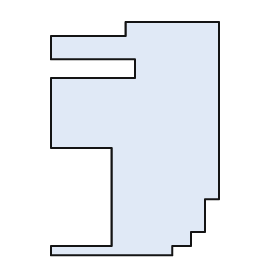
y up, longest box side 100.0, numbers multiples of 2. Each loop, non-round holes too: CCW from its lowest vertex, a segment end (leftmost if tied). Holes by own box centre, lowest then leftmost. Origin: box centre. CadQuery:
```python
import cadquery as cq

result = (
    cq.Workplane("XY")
    .moveTo(-36.0, -50.0)
    .lineTo(16.0, -50.0)
    .lineTo(16.0, -46.0)
    .lineTo(24.0, -46.0)
    .lineTo(24.0, -40.0)
    .lineTo(30.0, -40.0)
    .lineTo(30.0, -26.0)
    .lineTo(36.0, -26.0)
    .lineTo(36.0, 50.0)
    .lineTo(-4.0, 50.0)
    .lineTo(-4.0, 44.0)
    .lineTo(-36.0, 44.0)
    .lineTo(-36.0, 34.0)
    .lineTo(0.0, 34.0)
    .lineTo(0.0, 26.0)
    .lineTo(-36.0, 26.0)
    .lineTo(-36.0, -4.0)
    .lineTo(-10.0, -4.0)
    .lineTo(-10.0, -46.0)
    .lineTo(-36.0, -46.0)
    .close()
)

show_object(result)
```